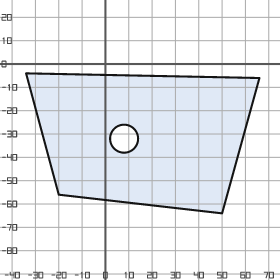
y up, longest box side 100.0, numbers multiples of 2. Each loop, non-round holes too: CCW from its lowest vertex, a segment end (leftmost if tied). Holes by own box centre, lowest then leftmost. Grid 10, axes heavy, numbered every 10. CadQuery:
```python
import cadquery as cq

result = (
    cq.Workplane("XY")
    .moveTo(50.0, -64.0)
    .lineTo(66.0, -6.0)
    .lineTo(-34.0, -4.0)
    .lineTo(-20.0, -56.0)
    .close()
    .moveTo(8.0, -32.0)
    .circle(6.0)
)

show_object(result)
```